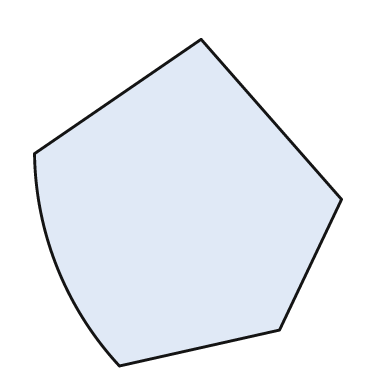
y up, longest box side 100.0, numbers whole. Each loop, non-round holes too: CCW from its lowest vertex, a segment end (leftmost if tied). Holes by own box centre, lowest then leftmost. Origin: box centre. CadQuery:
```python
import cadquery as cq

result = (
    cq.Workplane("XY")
    .moveTo(-21.0, -50.0)
    .lineTo(28.0, -39.0)
    .lineTo(47.0, 1.0)
    .lineTo(4.0, 50.0)
    .lineTo(-47.0, 15.0)
    .threePointArc((-40.0, -20.0), (-21.0, -50.0))
    .close()
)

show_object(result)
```